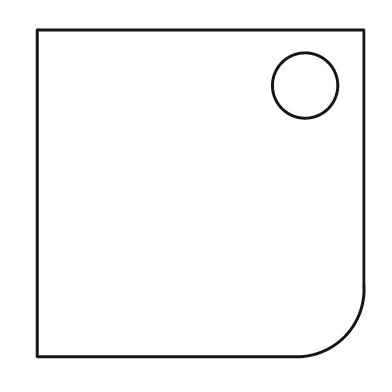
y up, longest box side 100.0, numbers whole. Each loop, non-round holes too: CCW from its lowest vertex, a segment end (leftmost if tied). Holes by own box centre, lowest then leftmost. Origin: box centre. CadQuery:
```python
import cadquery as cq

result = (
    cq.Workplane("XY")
    .moveTo(-50.0, -50.0)
    .lineTo(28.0, -50.0)
    .threePointArc((44.0, -44.0), (50.0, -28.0))
    .lineTo(50.0, 50.0)
    .lineTo(-50.0, 50.0)
    .close()
    .moveTo(32.0, 33.0)
    .circle(10.0)
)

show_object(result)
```